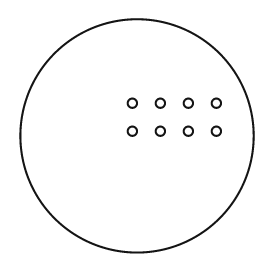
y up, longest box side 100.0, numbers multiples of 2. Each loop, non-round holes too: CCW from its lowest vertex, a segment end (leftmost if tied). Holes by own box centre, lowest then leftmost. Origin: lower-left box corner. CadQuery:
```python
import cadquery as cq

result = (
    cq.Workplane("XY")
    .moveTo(50.0, 50.0)
    .circle(50.0)
    .moveTo(48.0, 52.0)
    .circle(2.0)
    .moveTo(60.0, 52.0)
    .circle(2.0)
    .moveTo(72.0, 52.0)
    .circle(2.0)
    .moveTo(84.0, 52.0)
    .circle(2.0)
    .moveTo(48.0, 64.0)
    .circle(2.0)
    .moveTo(60.0, 64.0)
    .circle(2.0)
    .moveTo(72.0, 64.0)
    .circle(2.0)
    .moveTo(84.0, 64.0)
    .circle(2.0)
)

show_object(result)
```